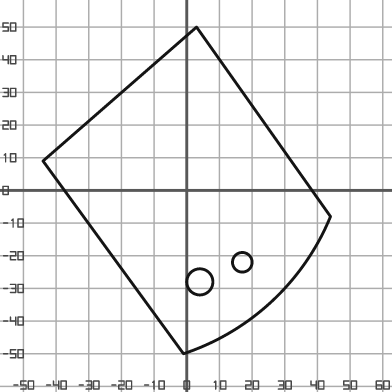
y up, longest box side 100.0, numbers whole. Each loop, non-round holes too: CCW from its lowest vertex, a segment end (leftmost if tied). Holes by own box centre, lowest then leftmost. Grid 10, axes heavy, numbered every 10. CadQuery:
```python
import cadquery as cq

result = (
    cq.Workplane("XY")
    .moveTo(-1.0, -50.0)
    .threePointArc((26.0, -34.0), (44.0, -8.0))
    .lineTo(3.0, 50.0)
    .lineTo(-44.0, 9.0)
    .close()
    .moveTo(4.0, -28.0)
    .circle(4.0)
    .moveTo(17.0, -22.0)
    .circle(3.0)
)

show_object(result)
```